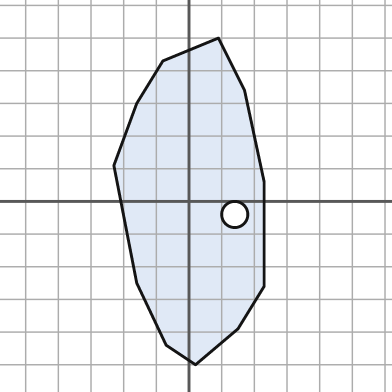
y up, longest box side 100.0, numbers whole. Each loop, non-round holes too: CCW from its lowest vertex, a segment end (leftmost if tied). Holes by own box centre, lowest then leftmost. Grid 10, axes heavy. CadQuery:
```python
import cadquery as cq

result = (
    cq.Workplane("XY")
    .moveTo(2.0, -50.0)
    .lineTo(15.0, -39.0)
    .lineTo(23.0, -26.0)
    .lineTo(23.0, 6.0)
    .lineTo(17.0, 34.0)
    .lineTo(9.0, 50.0)
    .lineTo(-8.0, 43.0)
    .lineTo(-16.0, 30.0)
    .lineTo(-23.0, 11.0)
    .lineTo(-16.0, -25.0)
    .lineTo(-7.0, -44.0)
    .close()
    .moveTo(14.0, -4.0)
    .circle(4.0)
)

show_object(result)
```